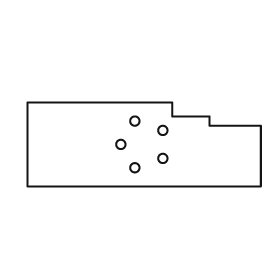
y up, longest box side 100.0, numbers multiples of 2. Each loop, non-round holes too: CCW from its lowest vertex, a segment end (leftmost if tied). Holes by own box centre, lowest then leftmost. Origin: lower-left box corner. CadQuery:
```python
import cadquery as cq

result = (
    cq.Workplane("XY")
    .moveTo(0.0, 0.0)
    .lineTo(100.0, 0.0)
    .lineTo(100.0, 26.0)
    .lineTo(78.0, 26.0)
    .lineTo(78.0, 30.0)
    .lineTo(62.0, 30.0)
    .lineTo(62.0, 36.0)
    .lineTo(0.0, 36.0)
    .close()
    .moveTo(46.0, 8.0)
    .circle(2.0)
    .moveTo(58.0, 12.0)
    .circle(2.0)
    .moveTo(40.0, 18.0)
    .circle(2.0)
    .moveTo(58.0, 24.0)
    .circle(2.0)
    .moveTo(46.0, 28.0)
    .circle(2.0)
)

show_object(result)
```